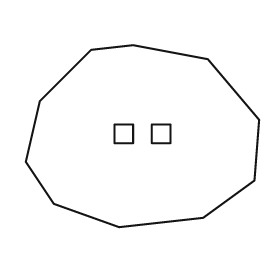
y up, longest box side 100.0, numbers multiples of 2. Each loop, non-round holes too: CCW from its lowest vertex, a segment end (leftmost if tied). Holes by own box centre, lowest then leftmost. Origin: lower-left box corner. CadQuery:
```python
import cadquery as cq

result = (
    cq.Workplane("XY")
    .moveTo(40.0, 0.0)
    .lineTo(76.0, 4.0)
    .lineTo(98.0, 20.0)
    .lineTo(100.0, 46.0)
    .lineTo(78.0, 72.0)
    .lineTo(46.0, 78.0)
    .lineTo(28.0, 76.0)
    .lineTo(6.0, 54.0)
    .lineTo(0.0, 28.0)
    .lineTo(12.0, 10.0)
    .close()
    .moveTo(38.0, 36.0)
    .lineTo(46.0, 36.0)
    .lineTo(46.0, 44.0)
    .lineTo(38.0, 44.0)
    .close()
    .moveTo(54.0, 36.0)
    .lineTo(62.0, 36.0)
    .lineTo(62.0, 44.0)
    .lineTo(54.0, 44.0)
    .close()
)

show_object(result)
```